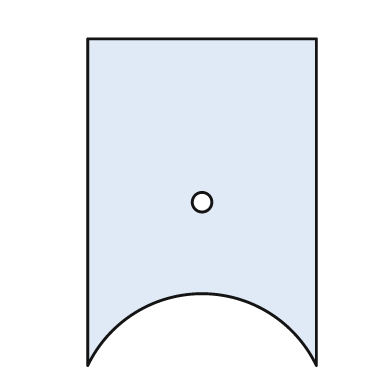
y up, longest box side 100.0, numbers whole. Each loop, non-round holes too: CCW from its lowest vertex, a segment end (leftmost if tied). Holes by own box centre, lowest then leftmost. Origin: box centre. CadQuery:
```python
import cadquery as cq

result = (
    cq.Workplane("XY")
    .moveTo(-35.0, -50.0)
    .threePointArc((0.0, -28.0), (35.0, -50.0))
    .lineTo(35.0, 50.0)
    .lineTo(-35.0, 50.0)
    .close()
    .moveTo(0.0, 0.0)
    .circle(3.0)
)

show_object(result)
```